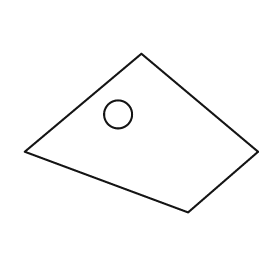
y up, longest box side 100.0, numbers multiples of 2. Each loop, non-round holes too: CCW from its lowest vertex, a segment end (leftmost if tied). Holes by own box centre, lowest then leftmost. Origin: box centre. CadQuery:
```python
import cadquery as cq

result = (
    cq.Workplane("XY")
    .moveTo(20.0, -34.0)
    .lineTo(50.0, -8.0)
    .lineTo(0.0, 34.0)
    .lineTo(-50.0, -8.0)
    .close()
    .moveTo(-10.0, 8.0)
    .circle(6.0)
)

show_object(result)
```